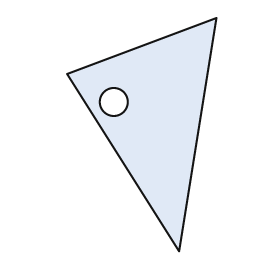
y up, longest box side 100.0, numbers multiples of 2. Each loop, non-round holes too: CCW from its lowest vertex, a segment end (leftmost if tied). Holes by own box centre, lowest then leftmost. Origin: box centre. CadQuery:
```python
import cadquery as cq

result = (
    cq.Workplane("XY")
    .moveTo(16.0, -50.0)
    .lineTo(32.0, 50.0)
    .lineTo(-32.0, 26.0)
    .close()
    .moveTo(-12.0, 14.0)
    .circle(6.0)
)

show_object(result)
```